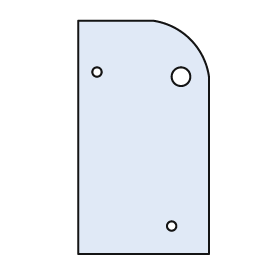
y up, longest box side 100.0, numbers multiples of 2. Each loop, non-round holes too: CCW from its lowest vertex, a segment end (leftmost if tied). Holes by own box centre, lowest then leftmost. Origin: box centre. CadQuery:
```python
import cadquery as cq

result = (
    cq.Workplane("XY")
    .moveTo(-28.0, -50.0)
    .lineTo(28.0, -50.0)
    .lineTo(28.0, 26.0)
    .threePointArc((20.0, 42.0), (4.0, 50.0))
    .lineTo(-28.0, 50.0)
    .close()
    .moveTo(12.0, -38.0)
    .circle(2.0)
    .moveTo(16.0, 26.0)
    .circle(4.0)
    .moveTo(-20.0, 28.0)
    .circle(2.0)
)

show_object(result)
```